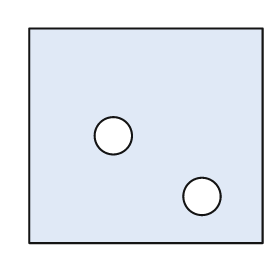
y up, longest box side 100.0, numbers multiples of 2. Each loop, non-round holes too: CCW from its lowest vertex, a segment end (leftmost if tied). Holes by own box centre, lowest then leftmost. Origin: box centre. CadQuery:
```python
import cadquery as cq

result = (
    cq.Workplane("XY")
    .moveTo(-50.0, -46.0)
    .lineTo(50.0, -46.0)
    .lineTo(50.0, 46.0)
    .lineTo(-50.0, 46.0)
    .close()
    .moveTo(24.0, -26.0)
    .circle(8.0)
    .moveTo(-14.0, 0.0)
    .circle(8.0)
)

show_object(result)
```